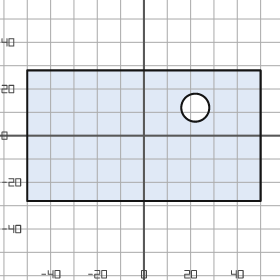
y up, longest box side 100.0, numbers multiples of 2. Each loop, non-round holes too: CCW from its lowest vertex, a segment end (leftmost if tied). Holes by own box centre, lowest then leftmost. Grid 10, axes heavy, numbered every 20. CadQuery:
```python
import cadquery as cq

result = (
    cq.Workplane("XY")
    .moveTo(-50.0, -28.0)
    .lineTo(50.0, -28.0)
    .lineTo(50.0, 28.0)
    .lineTo(-50.0, 28.0)
    .close()
    .moveTo(22.0, 12.0)
    .circle(6.0)
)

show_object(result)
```